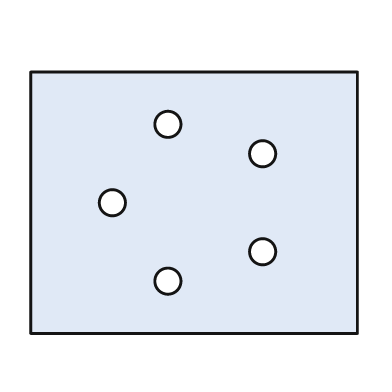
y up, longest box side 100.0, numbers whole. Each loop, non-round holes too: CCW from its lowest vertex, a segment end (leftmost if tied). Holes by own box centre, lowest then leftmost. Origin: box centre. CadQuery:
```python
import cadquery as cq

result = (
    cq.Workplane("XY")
    .moveTo(-50.0, -40.0)
    .lineTo(50.0, -40.0)
    .lineTo(50.0, 40.0)
    .lineTo(-50.0, 40.0)
    .close()
    .moveTo(-8.0, -24.0)
    .circle(4.0)
    .moveTo(21.0, -15.0)
    .circle(4.0)
    .moveTo(-25.0, 0.0)
    .circle(4.0)
    .moveTo(21.0, 15.0)
    .circle(4.0)
    .moveTo(-8.0, 24.0)
    .circle(4.0)
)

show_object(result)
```